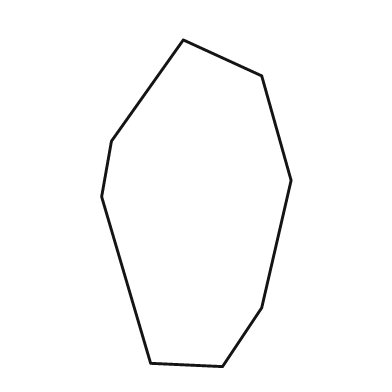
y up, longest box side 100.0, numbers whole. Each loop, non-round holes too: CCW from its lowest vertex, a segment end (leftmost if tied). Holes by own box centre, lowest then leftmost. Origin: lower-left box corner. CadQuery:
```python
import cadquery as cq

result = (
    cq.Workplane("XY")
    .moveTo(37.0, 0.0)
    .lineTo(49.0, 18.0)
    .lineTo(58.0, 57.0)
    .lineTo(49.0, 89.0)
    .lineTo(25.0, 100.0)
    .lineTo(3.0, 69.0)
    .lineTo(0.0, 52.0)
    .lineTo(15.0, 1.0)
    .close()
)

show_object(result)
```